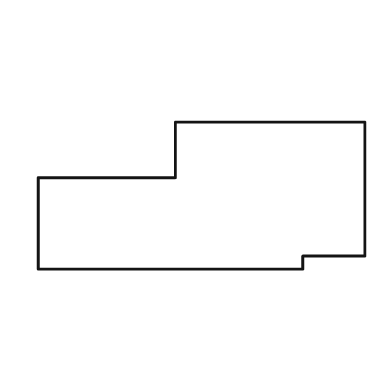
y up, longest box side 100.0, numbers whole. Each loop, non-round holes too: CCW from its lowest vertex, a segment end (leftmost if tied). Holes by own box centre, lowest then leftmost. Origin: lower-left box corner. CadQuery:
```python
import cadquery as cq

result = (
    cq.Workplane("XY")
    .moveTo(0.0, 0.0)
    .lineTo(81.0, 0.0)
    .lineTo(81.0, 4.0)
    .lineTo(100.0, 4.0)
    .lineTo(100.0, 45.0)
    .lineTo(42.0, 45.0)
    .lineTo(42.0, 28.0)
    .lineTo(0.0, 28.0)
    .close()
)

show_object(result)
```